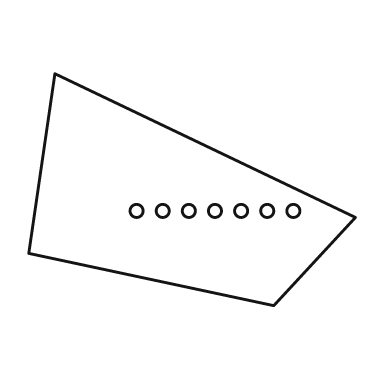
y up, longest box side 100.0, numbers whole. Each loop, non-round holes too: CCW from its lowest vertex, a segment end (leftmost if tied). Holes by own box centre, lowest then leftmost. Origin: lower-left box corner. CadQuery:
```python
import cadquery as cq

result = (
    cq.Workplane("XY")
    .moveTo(75.0, 0.0)
    .lineTo(100.0, 27.0)
    .lineTo(8.0, 71.0)
    .lineTo(0.0, 16.0)
    .close()
    .moveTo(33.0, 29.0)
    .circle(2.0)
    .moveTo(41.0, 29.0)
    .circle(2.0)
    .moveTo(49.0, 29.0)
    .circle(2.0)
    .moveTo(57.0, 29.0)
    .circle(2.0)
    .moveTo(65.0, 29.0)
    .circle(2.0)
    .moveTo(73.0, 29.0)
    .circle(2.0)
    .moveTo(81.0, 29.0)
    .circle(2.0)
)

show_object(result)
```